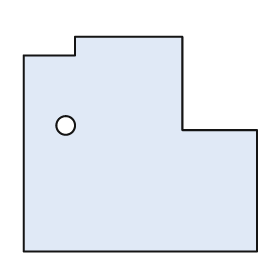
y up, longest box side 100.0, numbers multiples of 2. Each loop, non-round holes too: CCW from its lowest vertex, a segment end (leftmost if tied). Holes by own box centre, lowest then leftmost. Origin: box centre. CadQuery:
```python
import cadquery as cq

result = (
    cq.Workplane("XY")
    .moveTo(-50.0, -46.0)
    .lineTo(50.0, -46.0)
    .lineTo(50.0, 6.0)
    .lineTo(18.0, 6.0)
    .lineTo(18.0, 46.0)
    .lineTo(-28.0, 46.0)
    .lineTo(-28.0, 38.0)
    .lineTo(-50.0, 38.0)
    .close()
    .moveTo(-32.0, 8.0)
    .circle(4.0)
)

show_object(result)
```